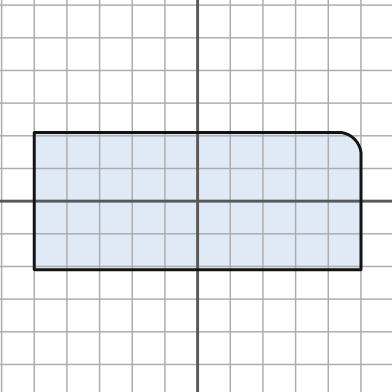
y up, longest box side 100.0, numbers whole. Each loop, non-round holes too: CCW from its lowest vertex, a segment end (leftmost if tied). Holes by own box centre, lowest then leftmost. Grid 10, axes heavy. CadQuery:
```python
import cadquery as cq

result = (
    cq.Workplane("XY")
    .moveTo(-50.0, -21.0)
    .lineTo(50.0, -21.0)
    .lineTo(50.0, 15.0)
    .threePointArc((48.0, 19.0), (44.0, 21.0))
    .lineTo(-50.0, 21.0)
    .close()
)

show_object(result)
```